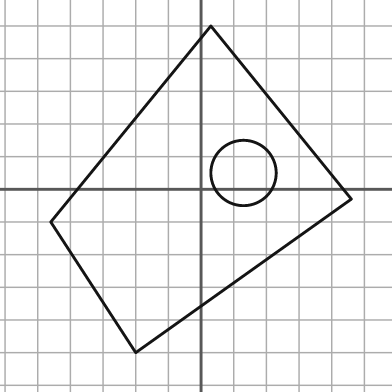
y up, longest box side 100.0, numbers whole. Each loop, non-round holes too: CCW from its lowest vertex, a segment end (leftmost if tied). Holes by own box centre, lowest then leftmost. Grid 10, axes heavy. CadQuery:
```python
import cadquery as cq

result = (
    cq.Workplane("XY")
    .moveTo(-20.0, -50.0)
    .lineTo(46.0, -3.0)
    .lineTo(3.0, 50.0)
    .lineTo(-46.0, -10.0)
    .close()
    .moveTo(13.0, 5.0)
    .circle(10.0)
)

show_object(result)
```